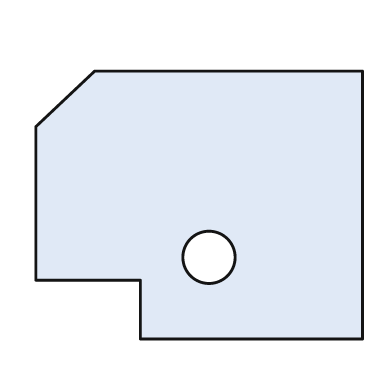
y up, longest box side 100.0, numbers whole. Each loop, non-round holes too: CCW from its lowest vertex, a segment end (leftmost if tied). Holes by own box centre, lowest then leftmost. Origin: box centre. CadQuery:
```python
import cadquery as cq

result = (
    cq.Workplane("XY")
    .moveTo(-18.0, -41.0)
    .lineTo(50.0, -41.0)
    .lineTo(50.0, 41.0)
    .lineTo(-32.0, 41.0)
    .lineTo(-50.0, 24.0)
    .lineTo(-50.0, -23.0)
    .lineTo(-18.0, -23.0)
    .close()
    .moveTo(3.0, -16.0)
    .circle(8.0)
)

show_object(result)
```